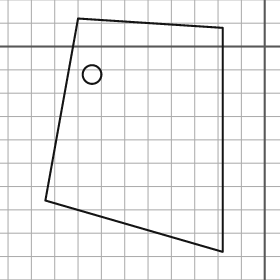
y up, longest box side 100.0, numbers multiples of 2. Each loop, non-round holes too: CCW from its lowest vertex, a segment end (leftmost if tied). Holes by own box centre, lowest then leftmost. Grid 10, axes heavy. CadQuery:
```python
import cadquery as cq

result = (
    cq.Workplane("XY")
    .moveTo(-18.0, -88.0)
    .lineTo(-18.0, 8.0)
    .lineTo(-80.0, 12.0)
    .lineTo(-94.0, -66.0)
    .close()
    .moveTo(-74.0, -12.0)
    .circle(4.0)
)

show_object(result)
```